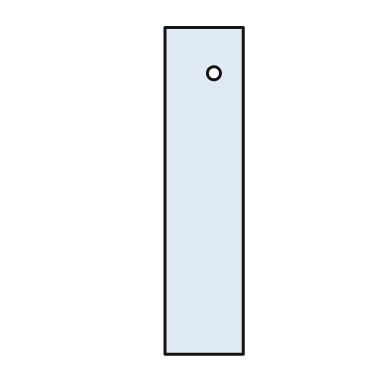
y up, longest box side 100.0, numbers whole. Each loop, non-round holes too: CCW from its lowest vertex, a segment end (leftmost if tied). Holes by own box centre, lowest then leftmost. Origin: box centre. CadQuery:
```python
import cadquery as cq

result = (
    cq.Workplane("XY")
    .moveTo(-12.0, -50.0)
    .lineTo(12.0, -50.0)
    .lineTo(12.0, 50.0)
    .lineTo(-12.0, 50.0)
    .close()
    .moveTo(3.0, 36.0)
    .circle(2.0)
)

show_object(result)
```